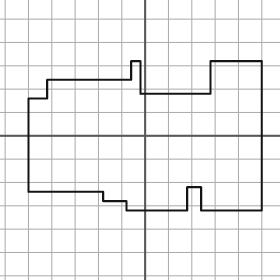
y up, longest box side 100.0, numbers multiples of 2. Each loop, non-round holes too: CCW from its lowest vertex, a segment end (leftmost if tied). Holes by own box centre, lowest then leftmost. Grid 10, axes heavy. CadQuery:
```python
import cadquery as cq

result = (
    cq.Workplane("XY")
    .moveTo(-8.0, -32.0)
    .lineTo(18.0, -32.0)
    .lineTo(18.0, -22.0)
    .lineTo(24.0, -22.0)
    .lineTo(24.0, -32.0)
    .lineTo(50.0, -32.0)
    .lineTo(50.0, 32.0)
    .lineTo(28.0, 32.0)
    .lineTo(28.0, 18.0)
    .lineTo(-2.0, 18.0)
    .lineTo(-2.0, 32.0)
    .lineTo(-6.0, 32.0)
    .lineTo(-6.0, 24.0)
    .lineTo(-42.0, 24.0)
    .lineTo(-42.0, 16.0)
    .lineTo(-50.0, 16.0)
    .lineTo(-50.0, -24.0)
    .lineTo(-18.0, -24.0)
    .lineTo(-18.0, -28.0)
    .lineTo(-8.0, -28.0)
    .close()
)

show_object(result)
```